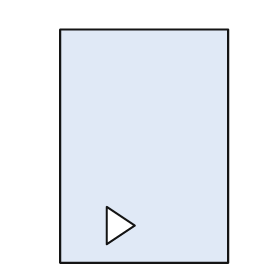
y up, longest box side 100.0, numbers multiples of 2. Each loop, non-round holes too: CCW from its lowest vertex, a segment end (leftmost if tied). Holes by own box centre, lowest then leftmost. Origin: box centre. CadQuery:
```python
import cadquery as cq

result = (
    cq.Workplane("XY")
    .moveTo(-36.0, -50.0)
    .lineTo(36.0, -50.0)
    .lineTo(36.0, 50.0)
    .lineTo(-36.0, 50.0)
    .close()
    .moveTo(-16.0, -42.0)
    .lineTo(-4.0, -34.0)
    .lineTo(-16.0, -26.0)
    .close()
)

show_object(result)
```